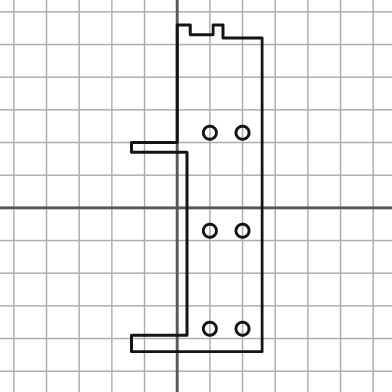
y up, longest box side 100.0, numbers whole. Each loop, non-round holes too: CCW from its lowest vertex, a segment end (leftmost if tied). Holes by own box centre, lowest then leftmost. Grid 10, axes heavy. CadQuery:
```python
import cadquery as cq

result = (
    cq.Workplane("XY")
    .moveTo(-14.0, -44.0)
    .lineTo(26.0, -44.0)
    .lineTo(26.0, 52.0)
    .lineTo(14.0, 52.0)
    .lineTo(14.0, 56.0)
    .lineTo(11.0, 56.0)
    .lineTo(11.0, 53.0)
    .lineTo(4.0, 53.0)
    .lineTo(4.0, 56.0)
    .lineTo(0.0, 56.0)
    .lineTo(0.0, 20.0)
    .lineTo(-14.0, 20.0)
    .lineTo(-14.0, 17.0)
    .lineTo(3.0, 17.0)
    .lineTo(3.0, -39.0)
    .lineTo(-14.0, -39.0)
    .close()
    .moveTo(10.0, -37.0)
    .circle(2.0)
    .moveTo(20.0, -37.0)
    .circle(2.0)
    .moveTo(10.0, -7.0)
    .circle(2.0)
    .moveTo(20.0, -7.0)
    .circle(2.0)
    .moveTo(10.0, 23.0)
    .circle(2.0)
    .moveTo(20.0, 23.0)
    .circle(2.0)
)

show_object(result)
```